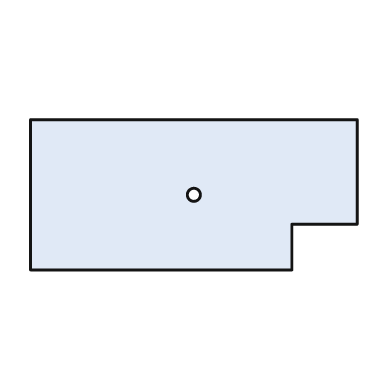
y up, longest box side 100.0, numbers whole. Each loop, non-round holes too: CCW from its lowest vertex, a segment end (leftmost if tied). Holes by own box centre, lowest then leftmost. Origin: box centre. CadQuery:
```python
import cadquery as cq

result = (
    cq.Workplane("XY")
    .moveTo(-50.0, -23.0)
    .lineTo(30.0, -23.0)
    .lineTo(30.0, -9.0)
    .lineTo(50.0, -9.0)
    .lineTo(50.0, 23.0)
    .lineTo(-50.0, 23.0)
    .close()
    .moveTo(0.0, 0.0)
    .circle(2.0)
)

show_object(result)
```